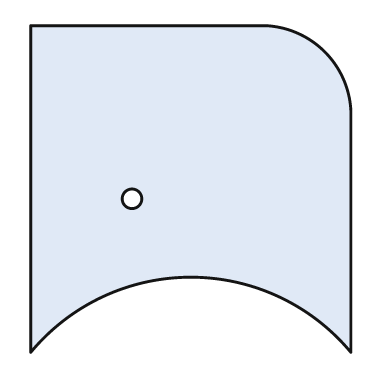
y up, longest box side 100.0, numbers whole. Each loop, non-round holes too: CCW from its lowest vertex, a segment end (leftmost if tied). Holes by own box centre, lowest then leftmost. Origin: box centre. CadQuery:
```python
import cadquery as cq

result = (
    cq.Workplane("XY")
    .moveTo(-49.0, -50.0)
    .threePointArc((0.0, -27.0), (49.0, -50.0))
    .lineTo(49.0, 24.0)
    .threePointArc((41.0, 42.0), (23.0, 50.0))
    .lineTo(-49.0, 50.0)
    .close()
    .moveTo(-18.0, -3.0)
    .circle(3.0)
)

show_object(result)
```